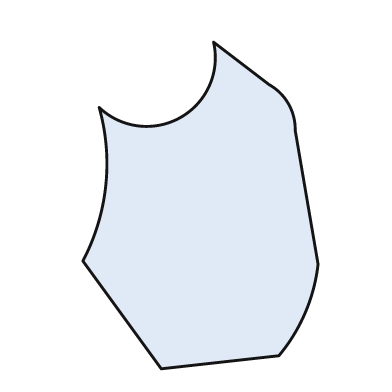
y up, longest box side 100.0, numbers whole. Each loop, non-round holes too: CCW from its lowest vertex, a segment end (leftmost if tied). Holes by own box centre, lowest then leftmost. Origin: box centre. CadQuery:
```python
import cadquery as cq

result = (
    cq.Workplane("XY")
    .moveTo(-12.0, -50.0)
    .lineTo(24.0, -46.0)
    .threePointArc((32.0, -33.0), (36.0, -18.0))
    .lineTo(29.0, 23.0)
    .threePointArc((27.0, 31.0), (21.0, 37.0))
    .lineTo(4.0, 50.0)
    .threePointArc((-6.0, 27.0), (-31.0, 30.0))
    .threePointArc((-29.0, 6.0), (-36.0, -17.0))
    .close()
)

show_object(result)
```